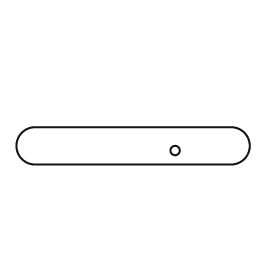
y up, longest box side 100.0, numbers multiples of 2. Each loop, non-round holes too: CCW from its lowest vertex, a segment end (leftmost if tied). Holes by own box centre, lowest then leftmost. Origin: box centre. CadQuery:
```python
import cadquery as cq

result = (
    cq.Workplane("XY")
    .moveTo(-42.0, -8.0)
    .lineTo(42.0, -8.0)
    .threePointArc((50.0, 0.0), (42.0, 8.0))
    .lineTo(-42.0, 8.0)
    .threePointArc((-50.0, 0.0), (-42.0, -8.0))
    .close()
    .moveTo(18.0, -2.0)
    .circle(2.0)
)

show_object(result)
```